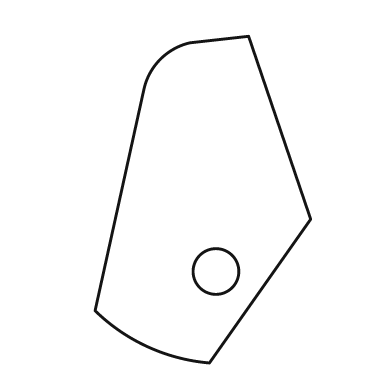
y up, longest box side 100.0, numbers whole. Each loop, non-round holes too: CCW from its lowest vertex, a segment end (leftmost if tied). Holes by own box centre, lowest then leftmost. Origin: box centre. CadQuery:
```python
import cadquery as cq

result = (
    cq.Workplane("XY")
    .moveTo(2.0, -50.0)
    .lineTo(33.0, -6.0)
    .lineTo(14.0, 50.0)
    .lineTo(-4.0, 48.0)
    .threePointArc((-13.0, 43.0), (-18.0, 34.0))
    .lineTo(-33.0, -34.0)
    .threePointArc((-17.0, -45.0), (2.0, -50.0))
    .close()
    .moveTo(4.0, -22.0)
    .circle(7.0)
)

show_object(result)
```